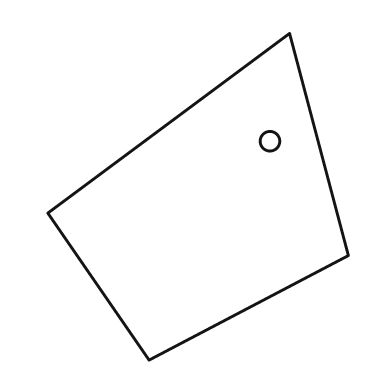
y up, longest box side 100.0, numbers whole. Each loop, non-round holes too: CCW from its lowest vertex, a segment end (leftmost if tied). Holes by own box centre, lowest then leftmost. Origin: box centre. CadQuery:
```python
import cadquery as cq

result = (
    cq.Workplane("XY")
    .moveTo(-15.0, -50.0)
    .lineTo(46.0, -18.0)
    .lineTo(28.0, 50.0)
    .lineTo(-46.0, -5.0)
    .close()
    .moveTo(22.0, 17.0)
    .circle(3.0)
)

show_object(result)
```